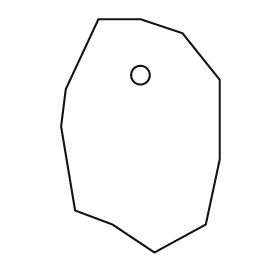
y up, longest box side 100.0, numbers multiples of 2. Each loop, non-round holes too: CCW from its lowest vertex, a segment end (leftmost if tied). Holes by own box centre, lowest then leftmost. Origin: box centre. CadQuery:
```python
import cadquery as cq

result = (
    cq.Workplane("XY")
    .moveTo(6.0, -50.0)
    .lineTo(28.0, -38.0)
    .lineTo(34.0, -10.0)
    .lineTo(34.0, 24.0)
    .lineTo(18.0, 44.0)
    .lineTo(0.0, 50.0)
    .lineTo(-18.0, 50.0)
    .lineTo(-32.0, 20.0)
    .lineTo(-34.0, 4.0)
    .lineTo(-28.0, -32.0)
    .lineTo(-12.0, -38.0)
    .close()
    .moveTo(0.0, 26.0)
    .circle(4.0)
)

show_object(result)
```